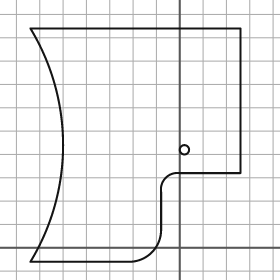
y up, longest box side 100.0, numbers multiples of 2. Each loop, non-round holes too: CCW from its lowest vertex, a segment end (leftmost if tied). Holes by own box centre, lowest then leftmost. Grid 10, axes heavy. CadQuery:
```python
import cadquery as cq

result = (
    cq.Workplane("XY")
    .moveTo(-64.0, -6.0)
    .lineTo(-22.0, -6.0)
    .threePointArc((-12.0, -2.0), (-8.0, 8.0))
    .lineTo(-8.0, 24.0)
    .threePointArc((-6.0, 30.0), (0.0, 32.0))
    .lineTo(26.0, 32.0)
    .lineTo(26.0, 94.0)
    .lineTo(-64.0, 94.0)
    .threePointArc((-50.0, 44.0), (-64.0, -6.0))
    .close()
    .moveTo(2.0, 42.0)
    .circle(2.0)
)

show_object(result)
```